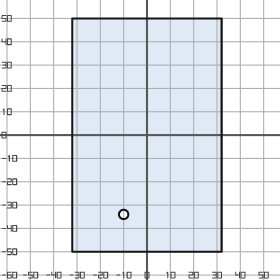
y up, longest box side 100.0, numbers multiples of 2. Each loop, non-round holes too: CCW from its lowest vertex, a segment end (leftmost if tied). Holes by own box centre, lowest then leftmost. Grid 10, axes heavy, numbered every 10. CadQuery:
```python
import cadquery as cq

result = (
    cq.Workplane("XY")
    .moveTo(-32.0, -50.0)
    .lineTo(32.0, -50.0)
    .lineTo(32.0, 50.0)
    .lineTo(-32.0, 50.0)
    .close()
    .moveTo(-10.0, -34.0)
    .circle(2.0)
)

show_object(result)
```